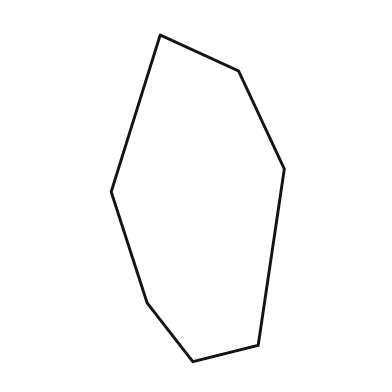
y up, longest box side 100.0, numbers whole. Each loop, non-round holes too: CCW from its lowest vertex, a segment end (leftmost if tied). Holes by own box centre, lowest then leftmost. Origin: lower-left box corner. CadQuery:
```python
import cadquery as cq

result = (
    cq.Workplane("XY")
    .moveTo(25.0, 0.0)
    .lineTo(45.0, 5.0)
    .lineTo(53.0, 59.0)
    .lineTo(39.0, 89.0)
    .lineTo(15.0, 100.0)
    .lineTo(0.0, 52.0)
    .lineTo(11.0, 18.0)
    .close()
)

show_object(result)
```